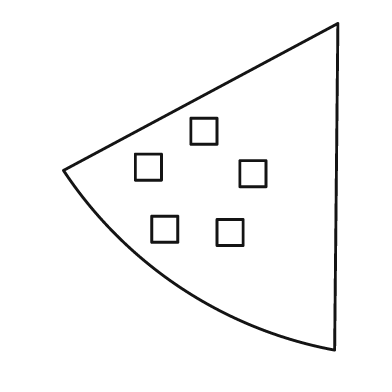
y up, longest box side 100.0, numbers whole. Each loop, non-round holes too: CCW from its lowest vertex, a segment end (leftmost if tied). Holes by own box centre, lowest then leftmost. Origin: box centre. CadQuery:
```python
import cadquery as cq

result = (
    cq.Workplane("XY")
    .moveTo(41.0, -50.0)
    .lineTo(42.0, 50.0)
    .lineTo(-42.0, 5.0)
    .threePointArc((-6.0, -31.0), (41.0, -50.0))
    .close()
    .moveTo(5.0, -18.0)
    .lineTo(13.0, -18.0)
    .lineTo(13.0, -10.0)
    .lineTo(5.0, -10.0)
    .close()
    .moveTo(-15.0, -17.0)
    .lineTo(-7.0, -17.0)
    .lineTo(-7.0, -9.0)
    .lineTo(-15.0, -9.0)
    .close()
    .moveTo(12.0, 0.0)
    .lineTo(20.0, 0.0)
    .lineTo(20.0, 8.0)
    .lineTo(12.0, 8.0)
    .close()
    .moveTo(-20.0, 2.0)
    .lineTo(-12.0, 2.0)
    .lineTo(-12.0, 10.0)
    .lineTo(-20.0, 10.0)
    .close()
    .moveTo(-3.0, 13.0)
    .lineTo(5.0, 13.0)
    .lineTo(5.0, 21.0)
    .lineTo(-3.0, 21.0)
    .close()
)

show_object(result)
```